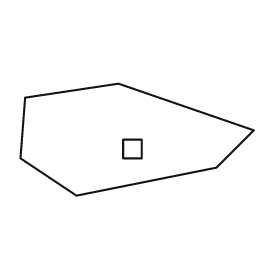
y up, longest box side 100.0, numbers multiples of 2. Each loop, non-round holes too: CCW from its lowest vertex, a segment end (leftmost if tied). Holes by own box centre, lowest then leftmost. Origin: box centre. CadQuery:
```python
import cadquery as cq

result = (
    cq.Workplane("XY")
    .moveTo(-26.0, -24.0)
    .lineTo(34.0, -12.0)
    .lineTo(50.0, 4.0)
    .lineTo(-8.0, 24.0)
    .lineTo(-48.0, 18.0)
    .lineTo(-50.0, -8.0)
    .close()
    .moveTo(-6.0, -8.0)
    .lineTo(2.0, -8.0)
    .lineTo(2.0, 0.0)
    .lineTo(-6.0, 0.0)
    .close()
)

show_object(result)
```